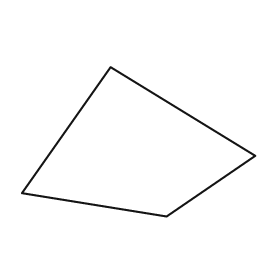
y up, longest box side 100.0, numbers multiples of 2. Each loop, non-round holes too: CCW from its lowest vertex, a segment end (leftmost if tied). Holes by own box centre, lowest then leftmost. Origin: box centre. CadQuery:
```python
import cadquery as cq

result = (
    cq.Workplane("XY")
    .moveTo(12.0, -32.0)
    .lineTo(50.0, -6.0)
    .lineTo(-12.0, 32.0)
    .lineTo(-50.0, -22.0)
    .close()
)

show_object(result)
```